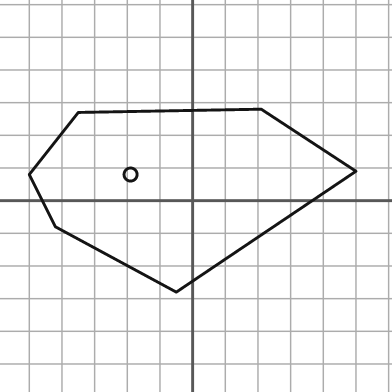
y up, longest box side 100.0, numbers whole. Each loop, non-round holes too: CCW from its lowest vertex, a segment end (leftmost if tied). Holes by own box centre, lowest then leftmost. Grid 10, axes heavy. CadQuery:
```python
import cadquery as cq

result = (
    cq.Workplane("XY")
    .moveTo(-5.0, -28.0)
    .lineTo(50.0, 9.0)
    .lineTo(21.0, 28.0)
    .lineTo(-35.0, 27.0)
    .lineTo(-50.0, 8.0)
    .lineTo(-42.0, -8.0)
    .close()
    .moveTo(-19.0, 8.0)
    .circle(2.0)
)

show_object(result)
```